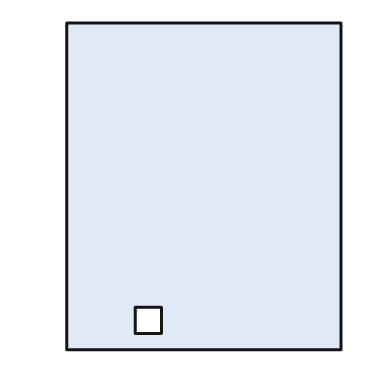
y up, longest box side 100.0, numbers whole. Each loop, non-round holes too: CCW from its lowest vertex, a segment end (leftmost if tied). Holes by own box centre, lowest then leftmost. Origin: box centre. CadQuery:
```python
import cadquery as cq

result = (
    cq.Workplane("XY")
    .moveTo(-42.0, -50.0)
    .lineTo(42.0, -50.0)
    .lineTo(42.0, 50.0)
    .lineTo(-42.0, 50.0)
    .close()
    .moveTo(-21.0, -45.0)
    .lineTo(-13.0, -45.0)
    .lineTo(-13.0, -37.0)
    .lineTo(-21.0, -37.0)
    .close()
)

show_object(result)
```